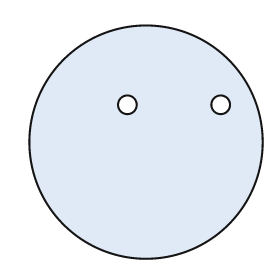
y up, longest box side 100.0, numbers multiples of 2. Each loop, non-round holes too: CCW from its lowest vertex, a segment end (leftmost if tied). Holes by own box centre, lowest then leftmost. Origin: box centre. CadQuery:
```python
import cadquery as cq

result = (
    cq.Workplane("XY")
    .moveTo(0.0, 0.0)
    .circle(50.0)
    .moveTo(-8.0, 16.0)
    .circle(4.0)
    .moveTo(32.0, 16.0)
    .circle(4.0)
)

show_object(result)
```